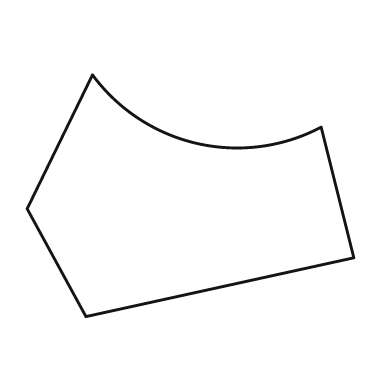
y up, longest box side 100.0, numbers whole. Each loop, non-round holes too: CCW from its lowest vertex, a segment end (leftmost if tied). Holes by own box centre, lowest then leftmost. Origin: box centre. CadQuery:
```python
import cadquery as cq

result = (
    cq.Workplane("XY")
    .moveTo(-32.0, -37.0)
    .lineTo(50.0, -19.0)
    .lineTo(40.0, 21.0)
    .threePointArc((2.0, 16.0), (-30.0, 37.0))
    .lineTo(-50.0, -4.0)
    .close()
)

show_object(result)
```